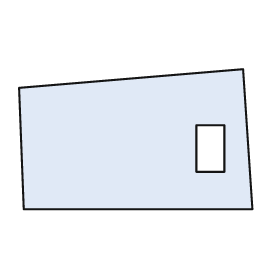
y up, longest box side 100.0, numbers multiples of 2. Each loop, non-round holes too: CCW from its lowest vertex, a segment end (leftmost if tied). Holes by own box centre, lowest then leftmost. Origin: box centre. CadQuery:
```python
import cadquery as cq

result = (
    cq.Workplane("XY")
    .moveTo(-48.0, -30.0)
    .lineTo(50.0, -30.0)
    .lineTo(46.0, 30.0)
    .lineTo(-50.0, 22.0)
    .close()
    .moveTo(26.0, -14.0)
    .lineTo(38.0, -14.0)
    .lineTo(38.0, 6.0)
    .lineTo(26.0, 6.0)
    .close()
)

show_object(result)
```